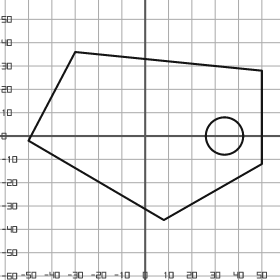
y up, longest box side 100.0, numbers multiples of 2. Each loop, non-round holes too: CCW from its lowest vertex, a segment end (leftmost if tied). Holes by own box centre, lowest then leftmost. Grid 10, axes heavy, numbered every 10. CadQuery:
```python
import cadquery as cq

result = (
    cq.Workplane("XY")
    .moveTo(8.0, -36.0)
    .lineTo(50.0, -12.0)
    .lineTo(50.0, 28.0)
    .lineTo(-30.0, 36.0)
    .lineTo(-50.0, -2.0)
    .close()
    .moveTo(34.0, 0.0)
    .circle(8.0)
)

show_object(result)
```